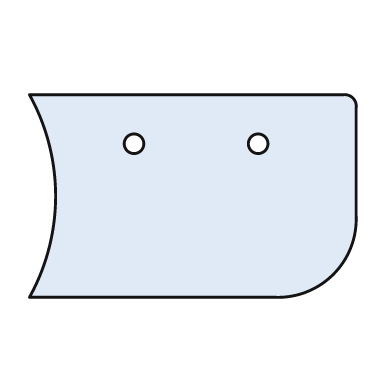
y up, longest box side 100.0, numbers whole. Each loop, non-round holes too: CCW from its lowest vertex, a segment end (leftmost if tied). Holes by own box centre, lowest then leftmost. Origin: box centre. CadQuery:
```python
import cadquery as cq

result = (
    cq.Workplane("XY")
    .moveTo(-50.0, -31.0)
    .lineTo(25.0, -31.0)
    .threePointArc((43.0, -24.0), (50.0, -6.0))
    .lineTo(50.0, 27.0)
    .threePointArc((49.0, 30.0), (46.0, 31.0))
    .lineTo(-50.0, 31.0)
    .threePointArc((-42.0, 0.0), (-50.0, -31.0))
    .close()
    .moveTo(-18.0, 16.0)
    .circle(3.0)
    .moveTo(20.0, 16.0)
    .circle(3.0)
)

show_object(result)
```